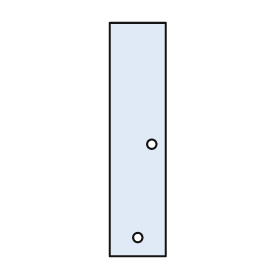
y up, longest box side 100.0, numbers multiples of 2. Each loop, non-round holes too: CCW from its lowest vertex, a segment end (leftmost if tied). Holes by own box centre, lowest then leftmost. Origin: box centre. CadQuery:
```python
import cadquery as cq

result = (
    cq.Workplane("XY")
    .moveTo(-12.0, -50.0)
    .lineTo(12.0, -50.0)
    .lineTo(12.0, 50.0)
    .lineTo(-12.0, 50.0)
    .close()
    .moveTo(0.0, -42.0)
    .circle(2.0)
    .moveTo(6.0, -2.0)
    .circle(2.0)
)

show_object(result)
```